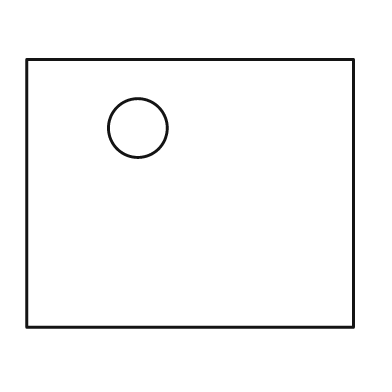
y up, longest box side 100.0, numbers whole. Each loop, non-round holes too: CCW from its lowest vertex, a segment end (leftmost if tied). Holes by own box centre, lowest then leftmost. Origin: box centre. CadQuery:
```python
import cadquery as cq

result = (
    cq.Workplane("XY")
    .moveTo(-50.0, -41.0)
    .lineTo(50.0, -41.0)
    .lineTo(50.0, 41.0)
    .lineTo(-50.0, 41.0)
    .close()
    .moveTo(-16.0, 20.0)
    .circle(9.0)
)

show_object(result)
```